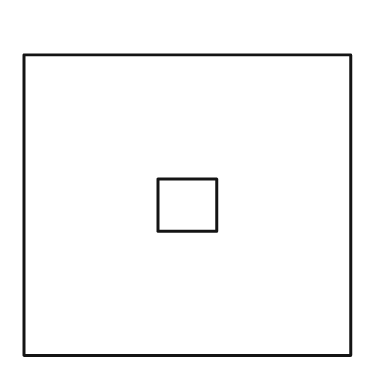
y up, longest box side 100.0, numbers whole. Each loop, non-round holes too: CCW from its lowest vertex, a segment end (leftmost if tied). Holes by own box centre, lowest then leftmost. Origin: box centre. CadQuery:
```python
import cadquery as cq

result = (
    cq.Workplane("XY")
    .moveTo(-50.0, -46.0)
    .lineTo(50.0, -46.0)
    .lineTo(50.0, 46.0)
    .lineTo(-50.0, 46.0)
    .close()
    .moveTo(-9.0, -8.0)
    .lineTo(9.0, -8.0)
    .lineTo(9.0, 8.0)
    .lineTo(-9.0, 8.0)
    .close()
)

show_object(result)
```